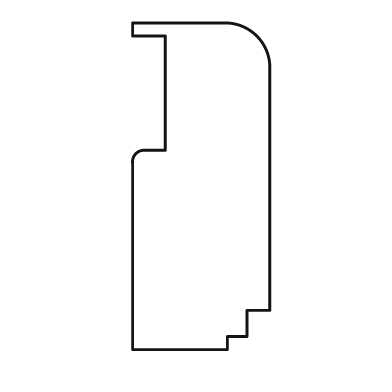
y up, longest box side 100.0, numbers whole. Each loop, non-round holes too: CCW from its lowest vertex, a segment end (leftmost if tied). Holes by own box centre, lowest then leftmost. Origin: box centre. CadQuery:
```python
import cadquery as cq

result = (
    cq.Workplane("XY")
    .moveTo(-21.0, -50.0)
    .lineTo(8.0, -50.0)
    .lineTo(8.0, -46.0)
    .lineTo(14.0, -46.0)
    .lineTo(14.0, -38.0)
    .lineTo(21.0, -38.0)
    .lineTo(21.0, 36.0)
    .threePointArc((17.0, 46.0), (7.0, 50.0))
    .lineTo(-21.0, 50.0)
    .lineTo(-21.0, 46.0)
    .lineTo(-11.0, 46.0)
    .lineTo(-11.0, 11.0)
    .lineTo(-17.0, 11.0)
    .threePointArc((-20.0, 10.0), (-21.0, 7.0))
    .close()
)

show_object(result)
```